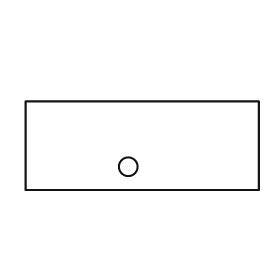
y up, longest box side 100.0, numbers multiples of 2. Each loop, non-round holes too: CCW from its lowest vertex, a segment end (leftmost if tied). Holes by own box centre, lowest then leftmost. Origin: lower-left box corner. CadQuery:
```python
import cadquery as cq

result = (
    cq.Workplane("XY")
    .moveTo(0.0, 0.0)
    .lineTo(100.0, 0.0)
    .lineTo(100.0, 38.0)
    .lineTo(0.0, 38.0)
    .close()
    .moveTo(44.0, 10.0)
    .circle(4.0)
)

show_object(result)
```